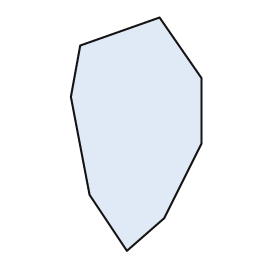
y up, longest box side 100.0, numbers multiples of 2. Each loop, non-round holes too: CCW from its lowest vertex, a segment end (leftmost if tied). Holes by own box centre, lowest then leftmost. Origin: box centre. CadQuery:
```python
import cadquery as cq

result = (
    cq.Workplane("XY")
    .moveTo(-4.0, -50.0)
    .lineTo(12.0, -36.0)
    .lineTo(28.0, -4.0)
    .lineTo(28.0, 24.0)
    .lineTo(10.0, 50.0)
    .lineTo(-24.0, 38.0)
    .lineTo(-28.0, 16.0)
    .lineTo(-20.0, -26.0)
    .close()
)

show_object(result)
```